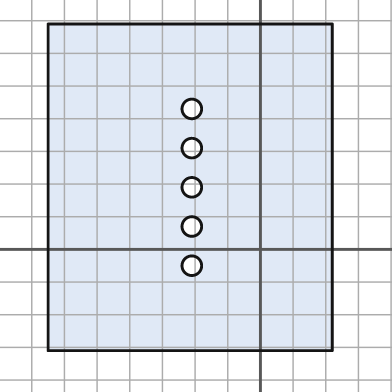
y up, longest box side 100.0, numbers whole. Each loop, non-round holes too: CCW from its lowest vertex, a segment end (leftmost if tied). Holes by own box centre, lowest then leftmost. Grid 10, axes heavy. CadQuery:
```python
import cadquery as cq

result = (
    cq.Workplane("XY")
    .moveTo(-65.0, -31.0)
    .lineTo(22.0, -31.0)
    .lineTo(22.0, 69.0)
    .lineTo(-65.0, 69.0)
    .close()
    .moveTo(-21.0, -5.0)
    .circle(3.0)
    .moveTo(-21.0, 7.0)
    .circle(3.0)
    .moveTo(-21.0, 19.0)
    .circle(3.0)
    .moveTo(-21.0, 31.0)
    .circle(3.0)
    .moveTo(-21.0, 43.0)
    .circle(3.0)
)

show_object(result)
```